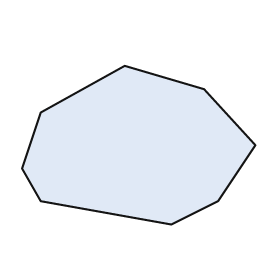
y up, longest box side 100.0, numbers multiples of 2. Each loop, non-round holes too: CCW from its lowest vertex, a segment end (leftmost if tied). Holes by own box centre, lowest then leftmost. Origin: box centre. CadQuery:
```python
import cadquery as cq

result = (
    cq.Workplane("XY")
    .moveTo(14.0, -34.0)
    .lineTo(34.0, -24.0)
    .lineTo(50.0, 0.0)
    .lineTo(28.0, 24.0)
    .lineTo(-6.0, 34.0)
    .lineTo(-42.0, 14.0)
    .lineTo(-50.0, -10.0)
    .lineTo(-42.0, -24.0)
    .close()
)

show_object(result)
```